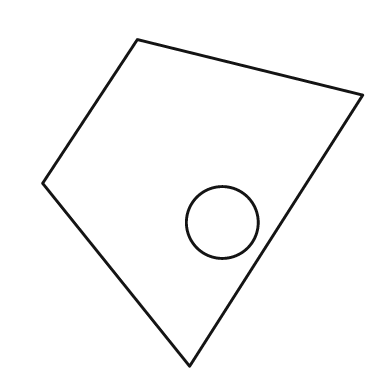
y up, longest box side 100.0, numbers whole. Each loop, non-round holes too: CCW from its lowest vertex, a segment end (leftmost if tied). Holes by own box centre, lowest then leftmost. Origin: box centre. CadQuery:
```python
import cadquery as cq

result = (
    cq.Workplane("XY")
    .moveTo(-4.0, -50.0)
    .lineTo(49.0, 33.0)
    .lineTo(-20.0, 50.0)
    .lineTo(-49.0, 6.0)
    .close()
    .moveTo(6.0, -6.0)
    .circle(11.0)
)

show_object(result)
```